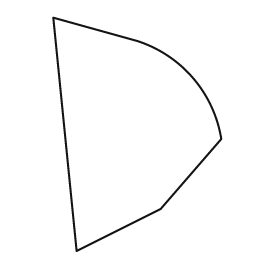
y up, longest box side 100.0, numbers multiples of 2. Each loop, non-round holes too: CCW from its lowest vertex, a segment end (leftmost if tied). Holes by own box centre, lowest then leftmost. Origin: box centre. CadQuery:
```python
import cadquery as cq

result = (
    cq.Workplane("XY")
    .moveTo(-26.0, -50.0)
    .lineTo(10.0, -32.0)
    .lineTo(36.0, -2.0)
    .threePointArc((24.0, 24.0), (0.0, 40.0))
    .lineTo(-36.0, 50.0)
    .close()
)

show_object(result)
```